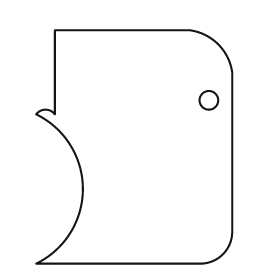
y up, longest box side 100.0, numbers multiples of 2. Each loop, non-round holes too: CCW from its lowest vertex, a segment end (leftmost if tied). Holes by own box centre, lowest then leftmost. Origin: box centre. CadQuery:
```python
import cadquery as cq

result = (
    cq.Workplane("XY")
    .moveTo(-42.0, -50.0)
    .lineTo(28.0, -50.0)
    .threePointArc((38.0, -46.0), (42.0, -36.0))
    .lineTo(42.0, 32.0)
    .threePointArc((36.0, 44.0), (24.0, 50.0))
    .lineTo(-34.0, 50.0)
    .lineTo(-34.0, 14.0)
    .threePointArc((-38.0, 16.0), (-42.0, 14.0))
    .threePointArc((-22.0, -18.0), (-42.0, -50.0))
    .close()
    .moveTo(32.0, 20.0)
    .circle(4.0)
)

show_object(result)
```